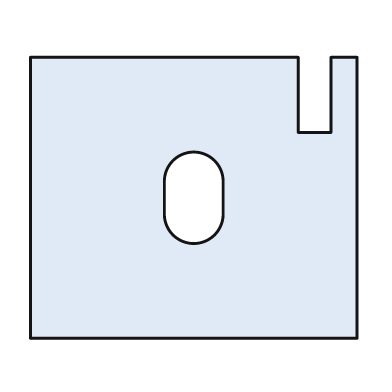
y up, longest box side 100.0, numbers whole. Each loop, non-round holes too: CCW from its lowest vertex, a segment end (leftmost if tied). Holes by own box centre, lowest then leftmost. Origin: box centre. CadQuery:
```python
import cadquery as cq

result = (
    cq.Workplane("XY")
    .moveTo(-50.0, -43.0)
    .lineTo(50.0, -43.0)
    .lineTo(50.0, 43.0)
    .lineTo(42.0, 43.0)
    .lineTo(42.0, 20.0)
    .lineTo(32.0, 20.0)
    .lineTo(32.0, 43.0)
    .lineTo(-50.0, 43.0)
    .close()
    .moveTo(-9.0, -5.0)
    .threePointArc((0.0, -14.0), (9.0, -5.0))
    .lineTo(9.0, 5.0)
    .threePointArc((0.0, 14.0), (-9.0, 5.0))
    .close()
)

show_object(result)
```